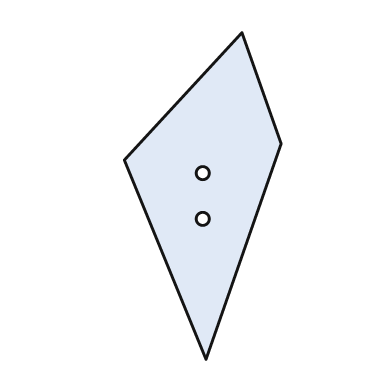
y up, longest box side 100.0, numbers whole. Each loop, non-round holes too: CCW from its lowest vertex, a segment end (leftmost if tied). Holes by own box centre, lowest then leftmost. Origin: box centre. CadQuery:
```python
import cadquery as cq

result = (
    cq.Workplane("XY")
    .moveTo(1.0, -50.0)
    .lineTo(24.0, 16.0)
    .lineTo(12.0, 50.0)
    .lineTo(-24.0, 11.0)
    .close()
    .moveTo(0.0, -7.0)
    .circle(2.0)
    .moveTo(0.0, 7.0)
    .circle(2.0)
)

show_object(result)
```